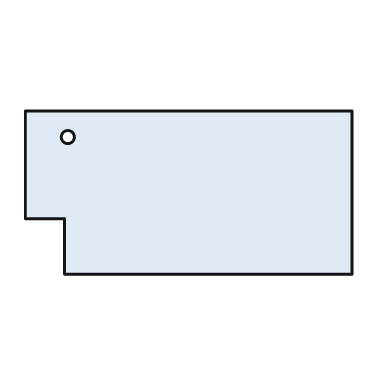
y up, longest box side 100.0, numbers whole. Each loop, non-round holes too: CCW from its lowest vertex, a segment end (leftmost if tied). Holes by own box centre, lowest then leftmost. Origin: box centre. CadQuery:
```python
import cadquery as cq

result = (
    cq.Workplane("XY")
    .moveTo(-38.0, -25.0)
    .lineTo(50.0, -25.0)
    .lineTo(50.0, 25.0)
    .lineTo(-50.0, 25.0)
    .lineTo(-50.0, -8.0)
    .lineTo(-38.0, -8.0)
    .close()
    .moveTo(-37.0, 17.0)
    .circle(2.0)
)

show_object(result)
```